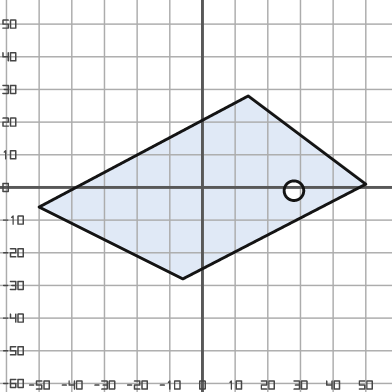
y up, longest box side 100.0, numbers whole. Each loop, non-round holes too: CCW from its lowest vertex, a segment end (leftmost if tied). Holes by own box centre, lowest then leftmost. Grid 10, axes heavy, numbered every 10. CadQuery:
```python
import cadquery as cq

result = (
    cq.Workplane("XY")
    .moveTo(-6.0, -28.0)
    .lineTo(50.0, 1.0)
    .lineTo(14.0, 28.0)
    .lineTo(-50.0, -6.0)
    .close()
    .moveTo(28.0, -1.0)
    .circle(3.0)
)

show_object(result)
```